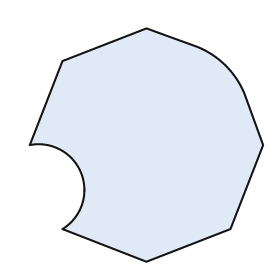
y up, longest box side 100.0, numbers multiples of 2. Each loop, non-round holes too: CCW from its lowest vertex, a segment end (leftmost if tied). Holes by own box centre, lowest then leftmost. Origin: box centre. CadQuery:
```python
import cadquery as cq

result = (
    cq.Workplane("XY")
    .moveTo(0.0, -50.0)
    .lineTo(36.0, -36.0)
    .lineTo(50.0, 0.0)
    .lineTo(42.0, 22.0)
    .threePointArc((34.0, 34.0), (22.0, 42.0))
    .lineTo(0.0, 50.0)
    .lineTo(-36.0, 36.0)
    .lineTo(-50.0, 0.0)
    .threePointArc((-28.0, -12.0), (-36.0, -36.0))
    .close()
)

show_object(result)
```